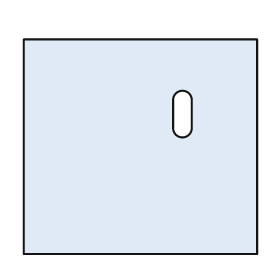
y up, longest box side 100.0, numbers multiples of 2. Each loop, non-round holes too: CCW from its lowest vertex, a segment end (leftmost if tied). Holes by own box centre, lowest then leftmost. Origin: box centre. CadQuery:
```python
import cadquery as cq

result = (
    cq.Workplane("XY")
    .moveTo(-50.0, -46.0)
    .lineTo(50.0, -46.0)
    .lineTo(50.0, 46.0)
    .lineTo(-50.0, 46.0)
    .close()
    .moveTo(14.0, 8.0)
    .threePointArc((18.0, 4.0), (22.0, 8.0))
    .lineTo(22.0, 20.0)
    .threePointArc((18.0, 24.0), (14.0, 20.0))
    .close()
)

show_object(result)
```